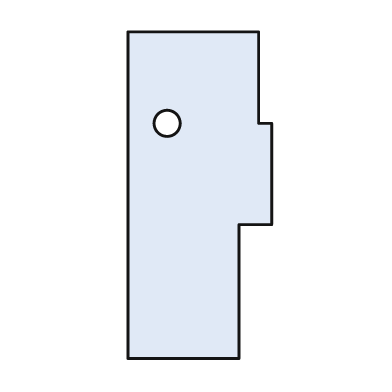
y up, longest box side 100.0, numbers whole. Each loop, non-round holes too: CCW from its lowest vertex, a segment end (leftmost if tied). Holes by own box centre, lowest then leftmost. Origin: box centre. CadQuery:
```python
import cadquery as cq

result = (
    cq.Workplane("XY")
    .moveTo(-22.0, -50.0)
    .lineTo(12.0, -50.0)
    .lineTo(12.0, -9.0)
    .lineTo(22.0, -9.0)
    .lineTo(22.0, 22.0)
    .lineTo(18.0, 22.0)
    .lineTo(18.0, 50.0)
    .lineTo(-22.0, 50.0)
    .close()
    .moveTo(-10.0, 22.0)
    .circle(4.0)
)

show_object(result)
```